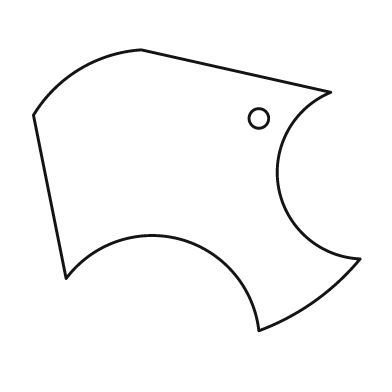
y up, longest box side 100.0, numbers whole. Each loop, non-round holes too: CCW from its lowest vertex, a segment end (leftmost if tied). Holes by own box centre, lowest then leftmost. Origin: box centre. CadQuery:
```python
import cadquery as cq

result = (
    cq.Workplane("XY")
    .moveTo(19.0, -43.0)
    .threePointArc((36.0, -34.0), (50.0, -21.0))
    .threePointArc((25.0, 1.0), (41.0, 30.0))
    .lineTo(-17.0, 43.0)
    .threePointArc((-36.0, 37.0), (-50.0, 23.0))
    .lineTo(-40.0, -27.0)
    .threePointArc((-5.0, -15.0), (19.0, -43.0))
    .close()
    .moveTo(19.0, 22.0)
    .circle(3.0)
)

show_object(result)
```